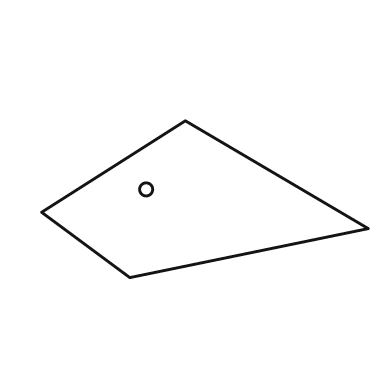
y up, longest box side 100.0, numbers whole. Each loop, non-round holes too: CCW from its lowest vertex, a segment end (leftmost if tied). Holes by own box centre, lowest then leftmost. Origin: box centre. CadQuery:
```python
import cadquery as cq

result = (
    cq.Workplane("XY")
    .moveTo(-23.0, -24.0)
    .lineTo(50.0, -9.0)
    .lineTo(-6.0, 24.0)
    .lineTo(-50.0, -4.0)
    .close()
    .moveTo(-18.0, 3.0)
    .circle(2.0)
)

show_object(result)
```